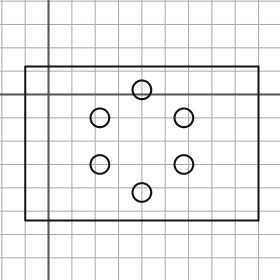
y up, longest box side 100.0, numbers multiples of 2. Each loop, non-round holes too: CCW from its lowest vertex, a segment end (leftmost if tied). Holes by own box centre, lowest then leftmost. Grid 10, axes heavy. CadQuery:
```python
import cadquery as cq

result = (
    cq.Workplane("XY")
    .moveTo(-10.0, -54.0)
    .lineTo(90.0, -54.0)
    .lineTo(90.0, 12.0)
    .lineTo(-10.0, 12.0)
    .close()
    .moveTo(40.0, -42.0)
    .circle(4.0)
    .moveTo(22.0, -30.0)
    .circle(4.0)
    .moveTo(58.0, -30.0)
    .circle(4.0)
    .moveTo(22.0, -10.0)
    .circle(4.0)
    .moveTo(58.0, -10.0)
    .circle(4.0)
    .moveTo(40.0, 2.0)
    .circle(4.0)
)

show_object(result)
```